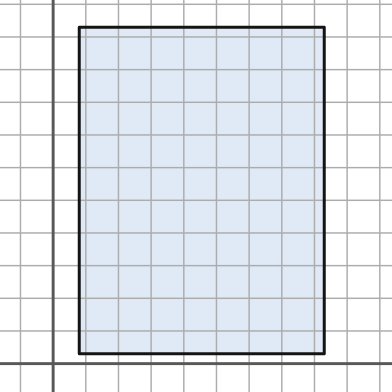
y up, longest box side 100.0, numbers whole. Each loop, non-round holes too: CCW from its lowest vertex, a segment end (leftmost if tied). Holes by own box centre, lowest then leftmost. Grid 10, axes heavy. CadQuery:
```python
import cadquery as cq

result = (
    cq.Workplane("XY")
    .moveTo(8.0, 3.0)
    .lineTo(83.0, 3.0)
    .lineTo(83.0, 103.0)
    .lineTo(8.0, 103.0)
    .close()
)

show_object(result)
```